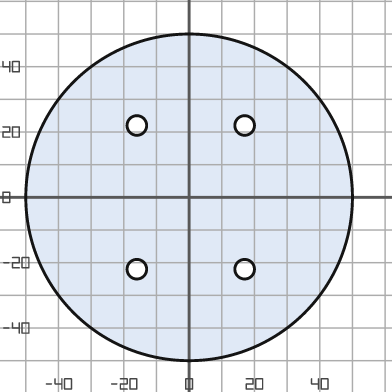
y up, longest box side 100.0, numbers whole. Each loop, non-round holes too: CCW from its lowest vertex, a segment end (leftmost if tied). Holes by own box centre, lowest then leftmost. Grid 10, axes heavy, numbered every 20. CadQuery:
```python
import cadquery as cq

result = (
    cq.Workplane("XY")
    .moveTo(0.0, 0.0)
    .circle(50.0)
    .moveTo(-16.0, -22.0)
    .circle(3.0)
    .moveTo(17.0, -22.0)
    .circle(3.0)
    .moveTo(-16.0, 22.0)
    .circle(3.0)
    .moveTo(17.0, 22.0)
    .circle(3.0)
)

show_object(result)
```